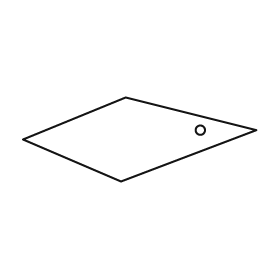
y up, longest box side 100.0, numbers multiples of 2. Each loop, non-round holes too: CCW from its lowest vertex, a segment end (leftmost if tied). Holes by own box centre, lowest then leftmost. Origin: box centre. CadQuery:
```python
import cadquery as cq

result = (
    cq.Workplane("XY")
    .moveTo(-8.0, -18.0)
    .lineTo(50.0, 4.0)
    .lineTo(-6.0, 18.0)
    .lineTo(-50.0, 0.0)
    .close()
    .moveTo(26.0, 4.0)
    .circle(2.0)
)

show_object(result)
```